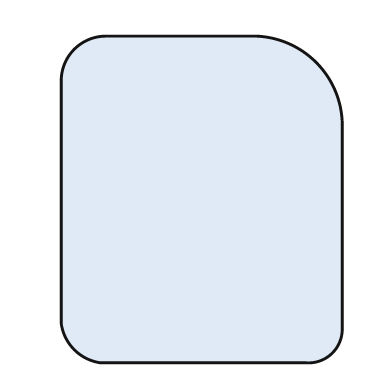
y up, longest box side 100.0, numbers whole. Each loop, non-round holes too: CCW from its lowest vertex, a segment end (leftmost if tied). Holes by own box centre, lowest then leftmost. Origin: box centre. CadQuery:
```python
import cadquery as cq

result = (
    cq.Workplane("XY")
    .moveTo(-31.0, -50.0)
    .lineTo(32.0, -50.0)
    .threePointArc((40.0, -47.0), (43.0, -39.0))
    .lineTo(43.0, 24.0)
    .threePointArc((35.0, 42.0), (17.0, 50.0))
    .lineTo(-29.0, 50.0)
    .threePointArc((-39.0, 46.0), (-43.0, 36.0))
    .lineTo(-43.0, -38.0)
    .threePointArc((-39.0, -46.0), (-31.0, -50.0))
    .close()
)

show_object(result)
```